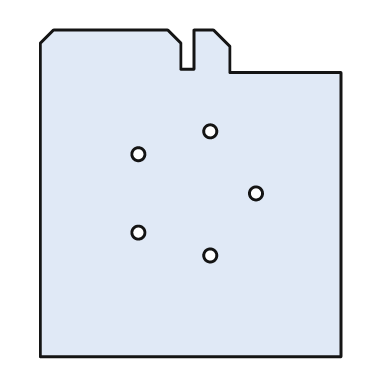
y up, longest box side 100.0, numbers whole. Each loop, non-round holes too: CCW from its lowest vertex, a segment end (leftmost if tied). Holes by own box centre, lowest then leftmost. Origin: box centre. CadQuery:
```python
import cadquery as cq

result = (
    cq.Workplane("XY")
    .moveTo(-46.0, -50.0)
    .lineTo(46.0, -50.0)
    .lineTo(46.0, 37.0)
    .lineTo(12.0, 37.0)
    .lineTo(12.0, 45.0)
    .lineTo(7.0, 50.0)
    .lineTo(1.0, 50.0)
    .lineTo(1.0, 38.0)
    .lineTo(-3.0, 38.0)
    .lineTo(-3.0, 46.0)
    .lineTo(-7.0, 50.0)
    .lineTo(-42.0, 50.0)
    .lineTo(-46.0, 46.0)
    .close()
    .moveTo(6.0, -19.0)
    .circle(2.0)
    .moveTo(-16.0, -12.0)
    .circle(2.0)
    .moveTo(20.0, 0.0)
    .circle(2.0)
    .moveTo(-16.0, 12.0)
    .circle(2.0)
    .moveTo(6.0, 19.0)
    .circle(2.0)
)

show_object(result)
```